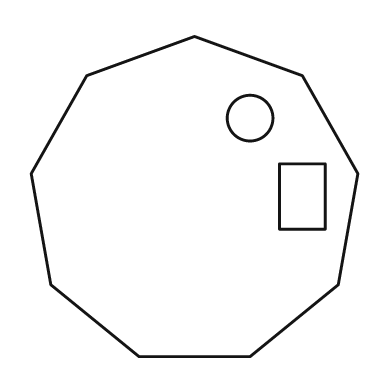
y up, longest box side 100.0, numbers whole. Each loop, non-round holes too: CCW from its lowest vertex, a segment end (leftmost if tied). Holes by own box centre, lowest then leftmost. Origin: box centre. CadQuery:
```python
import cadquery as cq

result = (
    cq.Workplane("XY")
    .moveTo(-17.0, -49.0)
    .lineTo(17.0, -49.0)
    .lineTo(44.0, -27.0)
    .lineTo(50.0, 7.0)
    .lineTo(33.0, 37.0)
    .lineTo(0.0, 49.0)
    .lineTo(-33.0, 37.0)
    .lineTo(-50.0, 7.0)
    .lineTo(-44.0, -27.0)
    .close()
    .moveTo(26.0, -10.0)
    .lineTo(40.0, -10.0)
    .lineTo(40.0, 10.0)
    .lineTo(26.0, 10.0)
    .close()
    .moveTo(17.0, 24.0)
    .circle(7.0)
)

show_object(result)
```